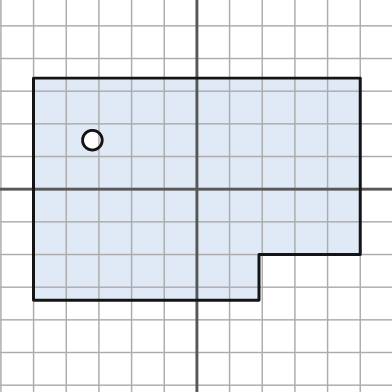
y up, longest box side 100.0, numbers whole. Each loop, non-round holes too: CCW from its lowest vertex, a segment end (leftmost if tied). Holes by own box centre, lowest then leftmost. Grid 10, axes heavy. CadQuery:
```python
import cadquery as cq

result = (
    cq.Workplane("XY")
    .moveTo(-50.0, -34.0)
    .lineTo(19.0, -34.0)
    .lineTo(19.0, -20.0)
    .lineTo(50.0, -20.0)
    .lineTo(50.0, 34.0)
    .lineTo(-50.0, 34.0)
    .close()
    .moveTo(-32.0, 15.0)
    .circle(3.0)
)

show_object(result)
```